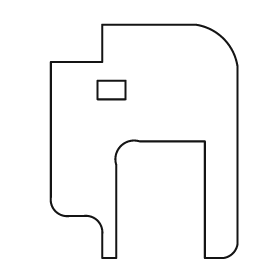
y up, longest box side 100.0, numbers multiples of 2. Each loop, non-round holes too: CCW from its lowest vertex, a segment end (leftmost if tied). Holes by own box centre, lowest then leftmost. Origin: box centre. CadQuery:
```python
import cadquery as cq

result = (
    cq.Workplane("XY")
    .moveTo(-18.0, -50.0)
    .lineTo(-12.0, -50.0)
    .lineTo(-12.0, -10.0)
    .threePointArc((-10.0, -2.0), (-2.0, 0.0))
    .lineTo(26.0, 0.0)
    .lineTo(26.0, -50.0)
    .lineTo(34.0, -50.0)
    .threePointArc((38.0, -48.0), (40.0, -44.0))
    .lineTo(40.0, 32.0)
    .threePointArc((34.0, 44.0), (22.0, 50.0))
    .lineTo(-18.0, 50.0)
    .lineTo(-18.0, 34.0)
    .lineTo(-40.0, 34.0)
    .lineTo(-40.0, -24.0)
    .threePointArc((-38.0, -30.0), (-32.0, -32.0))
    .lineTo(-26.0, -32.0)
    .threePointArc((-20.0, -34.0), (-18.0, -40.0))
    .close()
    .moveTo(-20.0, 18.0)
    .lineTo(-8.0, 18.0)
    .lineTo(-8.0, 26.0)
    .lineTo(-20.0, 26.0)
    .close()
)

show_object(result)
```